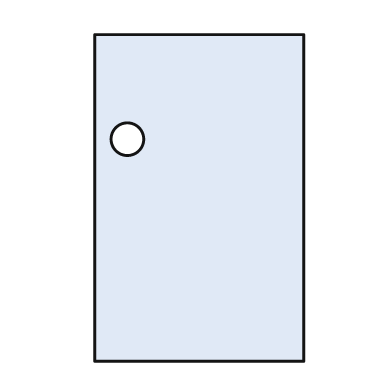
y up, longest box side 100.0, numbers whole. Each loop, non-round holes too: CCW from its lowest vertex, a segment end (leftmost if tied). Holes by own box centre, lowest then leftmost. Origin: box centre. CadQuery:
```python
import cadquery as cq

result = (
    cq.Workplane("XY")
    .moveTo(-32.0, -50.0)
    .lineTo(32.0, -50.0)
    .lineTo(32.0, 50.0)
    .lineTo(-32.0, 50.0)
    .close()
    .moveTo(-22.0, 18.0)
    .circle(5.0)
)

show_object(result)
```